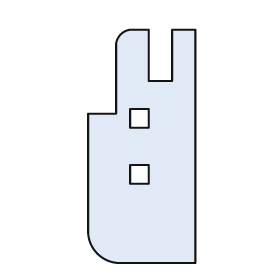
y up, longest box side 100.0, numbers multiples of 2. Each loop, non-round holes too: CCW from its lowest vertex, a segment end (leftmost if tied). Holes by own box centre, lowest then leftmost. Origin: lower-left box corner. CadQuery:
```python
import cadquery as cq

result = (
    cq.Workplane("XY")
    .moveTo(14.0, 0.0)
    .lineTo(46.0, 0.0)
    .lineTo(46.0, 100.0)
    .lineTo(36.0, 100.0)
    .lineTo(36.0, 78.0)
    .lineTo(26.0, 78.0)
    .lineTo(26.0, 100.0)
    .lineTo(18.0, 100.0)
    .threePointArc((14.0, 98.0), (12.0, 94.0))
    .lineTo(12.0, 64.0)
    .lineTo(0.0, 64.0)
    .lineTo(0.0, 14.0)
    .threePointArc((4.0, 4.0), (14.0, 0.0))
    .close()
    .moveTo(18.0, 34.0)
    .lineTo(26.0, 34.0)
    .lineTo(26.0, 42.0)
    .lineTo(18.0, 42.0)
    .close()
    .moveTo(18.0, 58.0)
    .lineTo(26.0, 58.0)
    .lineTo(26.0, 66.0)
    .lineTo(18.0, 66.0)
    .close()
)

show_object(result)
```